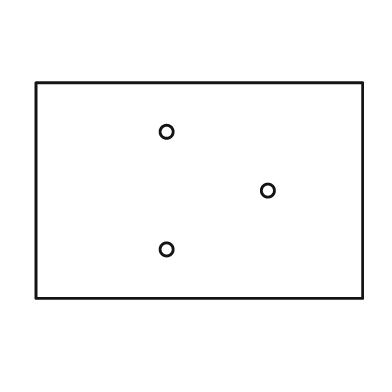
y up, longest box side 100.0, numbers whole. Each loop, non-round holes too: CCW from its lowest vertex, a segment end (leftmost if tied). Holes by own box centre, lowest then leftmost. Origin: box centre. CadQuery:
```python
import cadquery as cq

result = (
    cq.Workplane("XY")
    .moveTo(-50.0, -33.0)
    .lineTo(50.0, -33.0)
    .lineTo(50.0, 33.0)
    .lineTo(-50.0, 33.0)
    .close()
    .moveTo(-10.0, -18.0)
    .circle(2.0)
    .moveTo(21.0, 0.0)
    .circle(2.0)
    .moveTo(-10.0, 18.0)
    .circle(2.0)
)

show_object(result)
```